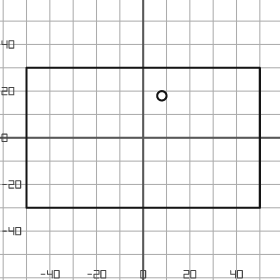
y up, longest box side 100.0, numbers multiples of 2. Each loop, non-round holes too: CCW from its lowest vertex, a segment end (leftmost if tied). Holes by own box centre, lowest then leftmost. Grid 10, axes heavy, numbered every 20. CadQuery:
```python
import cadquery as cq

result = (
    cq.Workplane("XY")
    .moveTo(-50.0, -30.0)
    .lineTo(50.0, -30.0)
    .lineTo(50.0, 30.0)
    .lineTo(-50.0, 30.0)
    .close()
    .moveTo(8.0, 18.0)
    .circle(2.0)
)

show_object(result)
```